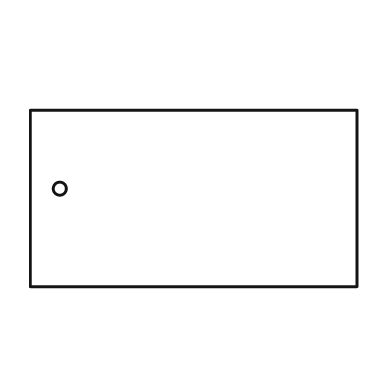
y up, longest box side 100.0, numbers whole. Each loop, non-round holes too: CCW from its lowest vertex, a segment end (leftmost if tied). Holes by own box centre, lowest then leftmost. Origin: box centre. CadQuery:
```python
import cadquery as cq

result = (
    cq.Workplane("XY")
    .moveTo(-50.0, -27.0)
    .lineTo(50.0, -27.0)
    .lineTo(50.0, 27.0)
    .lineTo(-50.0, 27.0)
    .close()
    .moveTo(-41.0, 3.0)
    .circle(2.0)
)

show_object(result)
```